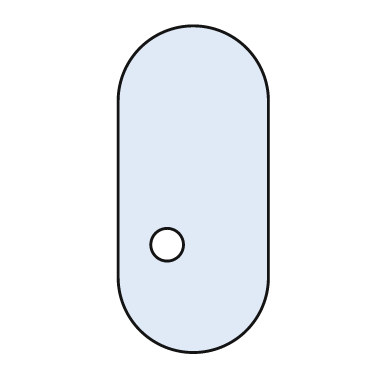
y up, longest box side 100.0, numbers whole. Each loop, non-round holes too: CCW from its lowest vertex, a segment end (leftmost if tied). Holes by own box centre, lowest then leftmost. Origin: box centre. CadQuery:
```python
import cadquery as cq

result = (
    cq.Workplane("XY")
    .moveTo(-23.0, -27.0)
    .threePointArc((0.0, -50.0), (23.0, -27.0))
    .lineTo(23.0, 27.0)
    .threePointArc((0.0, 50.0), (-23.0, 27.0))
    .close()
    .moveTo(-8.0, -17.0)
    .circle(5.0)
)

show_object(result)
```